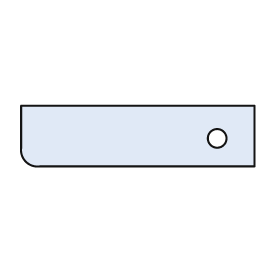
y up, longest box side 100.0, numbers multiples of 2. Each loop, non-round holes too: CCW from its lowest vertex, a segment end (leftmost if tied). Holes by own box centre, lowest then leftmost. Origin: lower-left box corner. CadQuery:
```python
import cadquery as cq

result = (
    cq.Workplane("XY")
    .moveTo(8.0, 0.0)
    .lineTo(100.0, 0.0)
    .lineTo(100.0, 26.0)
    .lineTo(0.0, 26.0)
    .lineTo(0.0, 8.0)
    .threePointArc((2.0, 2.0), (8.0, 0.0))
    .close()
    .moveTo(84.0, 12.0)
    .circle(4.0)
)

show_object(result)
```